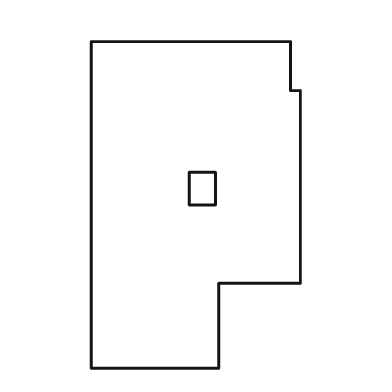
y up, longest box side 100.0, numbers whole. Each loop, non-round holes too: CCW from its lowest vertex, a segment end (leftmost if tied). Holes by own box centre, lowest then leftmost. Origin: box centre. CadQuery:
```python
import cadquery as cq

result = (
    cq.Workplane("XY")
    .moveTo(-32.0, -50.0)
    .lineTo(7.0, -50.0)
    .lineTo(7.0, -24.0)
    .lineTo(32.0, -24.0)
    .lineTo(32.0, 35.0)
    .lineTo(29.0, 35.0)
    .lineTo(29.0, 50.0)
    .lineTo(-32.0, 50.0)
    .close()
    .moveTo(-2.0, 0.0)
    .lineTo(6.0, 0.0)
    .lineTo(6.0, 10.0)
    .lineTo(-2.0, 10.0)
    .close()
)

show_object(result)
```